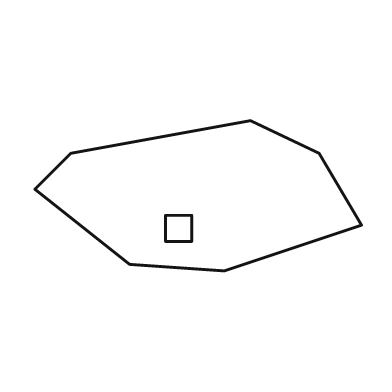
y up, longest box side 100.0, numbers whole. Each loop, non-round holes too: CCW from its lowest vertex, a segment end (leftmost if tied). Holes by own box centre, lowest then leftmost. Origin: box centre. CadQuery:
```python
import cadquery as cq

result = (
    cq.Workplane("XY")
    .moveTo(8.0, -23.0)
    .lineTo(50.0, -9.0)
    .lineTo(37.0, 13.0)
    .lineTo(16.0, 23.0)
    .lineTo(-39.0, 13.0)
    .lineTo(-50.0, 2.0)
    .lineTo(-21.0, -21.0)
    .close()
    .moveTo(-10.0, -14.0)
    .lineTo(-2.0, -14.0)
    .lineTo(-2.0, -6.0)
    .lineTo(-10.0, -6.0)
    .close()
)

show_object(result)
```